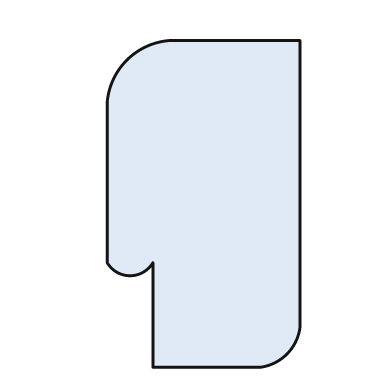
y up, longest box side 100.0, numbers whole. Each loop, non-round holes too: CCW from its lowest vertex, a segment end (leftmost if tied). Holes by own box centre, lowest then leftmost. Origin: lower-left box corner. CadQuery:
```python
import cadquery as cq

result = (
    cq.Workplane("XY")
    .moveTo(14.0, 0.0)
    .lineTo(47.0, 0.0)
    .threePointArc((55.0, 4.0), (59.0, 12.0))
    .lineTo(59.0, 100.0)
    .lineTo(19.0, 100.0)
    .threePointArc((6.0, 94.0), (0.0, 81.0))
    .lineTo(0.0, 32.0)
    .threePointArc((7.0, 28.0), (14.0, 32.0))
    .close()
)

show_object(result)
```